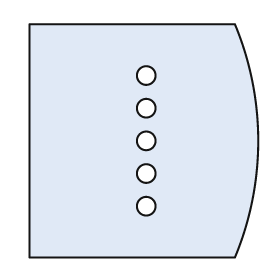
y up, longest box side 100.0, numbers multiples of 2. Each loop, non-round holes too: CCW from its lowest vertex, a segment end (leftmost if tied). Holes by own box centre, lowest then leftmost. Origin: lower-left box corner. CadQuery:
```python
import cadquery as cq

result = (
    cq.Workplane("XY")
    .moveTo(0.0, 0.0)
    .lineTo(88.0, 0.0)
    .threePointArc((98.0, 50.0), (88.0, 100.0))
    .lineTo(0.0, 100.0)
    .close()
    .moveTo(50.0, 22.0)
    .circle(4.0)
    .moveTo(50.0, 36.0)
    .circle(4.0)
    .moveTo(50.0, 50.0)
    .circle(4.0)
    .moveTo(50.0, 64.0)
    .circle(4.0)
    .moveTo(50.0, 78.0)
    .circle(4.0)
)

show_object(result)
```